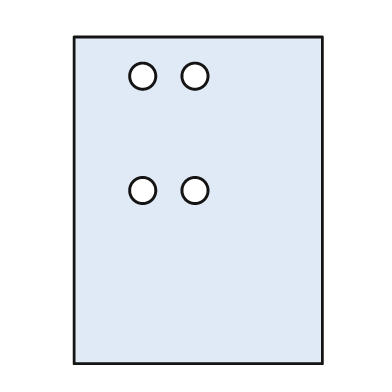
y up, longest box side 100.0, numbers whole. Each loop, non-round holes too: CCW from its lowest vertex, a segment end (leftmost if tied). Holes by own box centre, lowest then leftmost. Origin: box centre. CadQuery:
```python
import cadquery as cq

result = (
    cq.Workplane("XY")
    .moveTo(-38.0, -50.0)
    .lineTo(38.0, -50.0)
    .lineTo(38.0, 50.0)
    .lineTo(-38.0, 50.0)
    .close()
    .moveTo(-17.0, 3.0)
    .circle(4.0)
    .moveTo(-1.0, 3.0)
    .circle(4.0)
    .moveTo(-17.0, 38.0)
    .circle(4.0)
    .moveTo(-1.0, 38.0)
    .circle(4.0)
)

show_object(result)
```